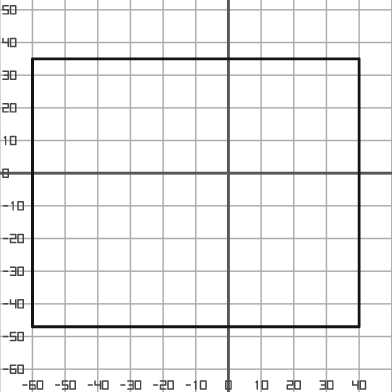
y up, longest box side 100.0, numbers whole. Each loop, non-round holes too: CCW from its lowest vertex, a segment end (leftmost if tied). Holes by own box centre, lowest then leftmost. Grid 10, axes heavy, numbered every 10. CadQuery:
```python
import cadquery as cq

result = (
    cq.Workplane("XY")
    .moveTo(-60.0, -47.0)
    .lineTo(40.0, -47.0)
    .lineTo(40.0, 35.0)
    .lineTo(-60.0, 35.0)
    .close()
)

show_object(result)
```